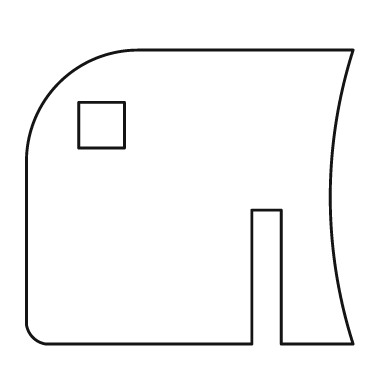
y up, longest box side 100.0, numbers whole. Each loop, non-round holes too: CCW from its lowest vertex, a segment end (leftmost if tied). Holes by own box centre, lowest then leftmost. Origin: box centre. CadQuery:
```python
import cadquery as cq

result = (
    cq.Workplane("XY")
    .moveTo(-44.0, -45.0)
    .lineTo(19.0, -45.0)
    .lineTo(19.0, -4.0)
    .lineTo(28.0, -4.0)
    .lineTo(28.0, -45.0)
    .lineTo(50.0, -45.0)
    .threePointArc((43.0, 0.0), (50.0, 45.0))
    .lineTo(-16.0, 45.0)
    .threePointArc((-40.0, 35.0), (-50.0, 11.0))
    .lineTo(-50.0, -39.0)
    .threePointArc((-48.0, -43.0), (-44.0, -45.0))
    .close()
    .moveTo(-34.0, 15.0)
    .lineTo(-20.0, 15.0)
    .lineTo(-20.0, 29.0)
    .lineTo(-34.0, 29.0)
    .close()
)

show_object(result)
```